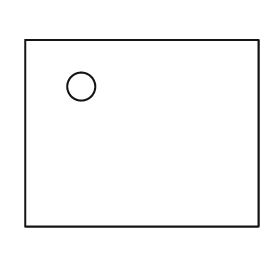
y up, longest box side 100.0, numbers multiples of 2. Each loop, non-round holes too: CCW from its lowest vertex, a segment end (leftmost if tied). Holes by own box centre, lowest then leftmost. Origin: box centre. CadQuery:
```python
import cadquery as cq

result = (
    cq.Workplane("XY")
    .moveTo(-50.0, -40.0)
    .lineTo(50.0, -40.0)
    .lineTo(50.0, 40.0)
    .lineTo(-50.0, 40.0)
    .close()
    .moveTo(-26.0, 20.0)
    .circle(6.0)
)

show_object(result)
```